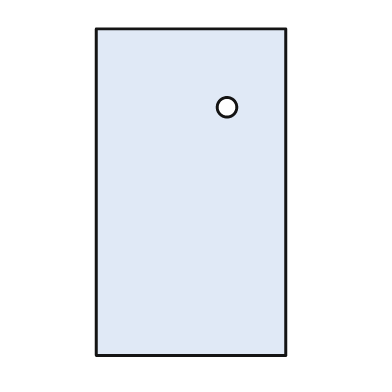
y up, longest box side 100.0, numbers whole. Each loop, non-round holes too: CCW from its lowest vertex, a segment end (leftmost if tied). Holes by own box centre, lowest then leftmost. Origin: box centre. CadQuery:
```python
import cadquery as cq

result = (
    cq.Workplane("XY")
    .moveTo(-29.0, -50.0)
    .lineTo(29.0, -50.0)
    .lineTo(29.0, 50.0)
    .lineTo(-29.0, 50.0)
    .close()
    .moveTo(11.0, 26.0)
    .circle(3.0)
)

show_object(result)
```